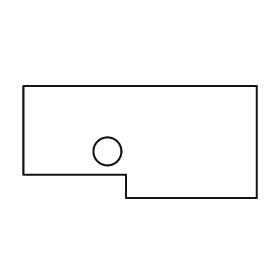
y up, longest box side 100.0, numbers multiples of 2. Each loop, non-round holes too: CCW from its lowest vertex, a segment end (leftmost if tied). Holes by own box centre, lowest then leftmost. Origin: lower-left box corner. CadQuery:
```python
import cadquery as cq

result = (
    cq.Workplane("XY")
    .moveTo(44.0, 0.0)
    .lineTo(100.0, 0.0)
    .lineTo(100.0, 48.0)
    .lineTo(0.0, 48.0)
    .lineTo(0.0, 10.0)
    .lineTo(44.0, 10.0)
    .close()
    .moveTo(36.0, 20.0)
    .circle(6.0)
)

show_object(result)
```